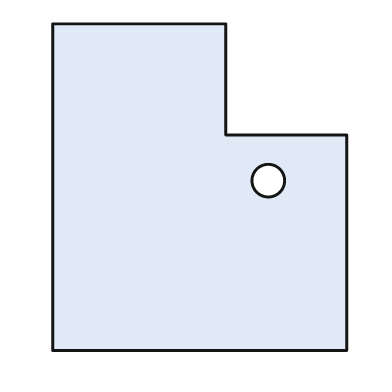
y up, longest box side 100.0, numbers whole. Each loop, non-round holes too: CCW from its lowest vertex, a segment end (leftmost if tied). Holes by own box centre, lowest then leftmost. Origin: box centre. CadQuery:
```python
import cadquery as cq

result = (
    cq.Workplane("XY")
    .moveTo(-45.0, -50.0)
    .lineTo(45.0, -50.0)
    .lineTo(45.0, 16.0)
    .lineTo(8.0, 16.0)
    .lineTo(8.0, 50.0)
    .lineTo(-45.0, 50.0)
    .close()
    .moveTo(21.0, 2.0)
    .circle(5.0)
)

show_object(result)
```